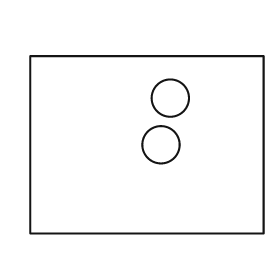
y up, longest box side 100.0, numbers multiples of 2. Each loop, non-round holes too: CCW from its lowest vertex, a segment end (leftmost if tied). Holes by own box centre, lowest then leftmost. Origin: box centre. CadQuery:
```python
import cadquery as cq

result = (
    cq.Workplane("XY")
    .moveTo(-50.0, -38.0)
    .lineTo(50.0, -38.0)
    .lineTo(50.0, 38.0)
    .lineTo(-50.0, 38.0)
    .close()
    .moveTo(6.0, 0.0)
    .circle(8.0)
    .moveTo(10.0, 20.0)
    .circle(8.0)
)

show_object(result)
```